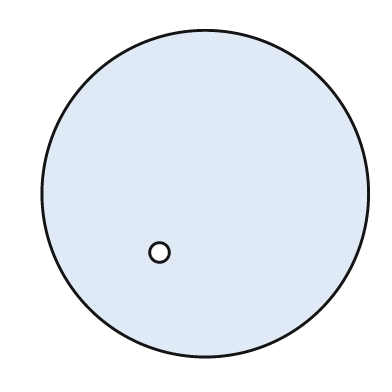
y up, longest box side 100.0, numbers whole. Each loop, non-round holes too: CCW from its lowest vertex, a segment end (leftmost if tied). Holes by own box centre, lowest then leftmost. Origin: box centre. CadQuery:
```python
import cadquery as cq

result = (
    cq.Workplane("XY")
    .moveTo(0.0, 0.0)
    .circle(50.0)
    .moveTo(-14.0, -18.0)
    .circle(3.0)
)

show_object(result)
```